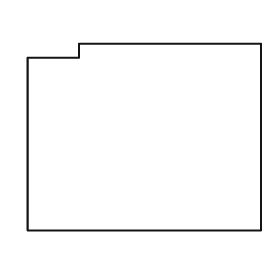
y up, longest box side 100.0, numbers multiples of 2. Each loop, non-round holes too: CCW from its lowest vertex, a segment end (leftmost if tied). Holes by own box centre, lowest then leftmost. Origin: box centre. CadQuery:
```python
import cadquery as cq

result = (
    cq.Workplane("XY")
    .moveTo(-50.0, -40.0)
    .lineTo(50.0, -40.0)
    .lineTo(50.0, 40.0)
    .lineTo(-28.0, 40.0)
    .lineTo(-28.0, 34.0)
    .lineTo(-50.0, 34.0)
    .close()
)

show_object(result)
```